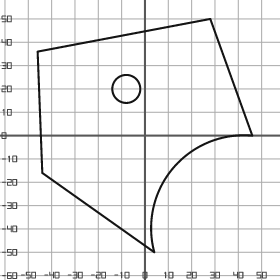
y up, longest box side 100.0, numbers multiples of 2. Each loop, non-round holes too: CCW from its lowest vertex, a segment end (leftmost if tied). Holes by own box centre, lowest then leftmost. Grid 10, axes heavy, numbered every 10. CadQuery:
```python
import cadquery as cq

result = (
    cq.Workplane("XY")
    .moveTo(4.0, -50.0)
    .threePointArc((12.0, -14.0), (46.0, 0.0))
    .lineTo(28.0, 50.0)
    .lineTo(-46.0, 36.0)
    .lineTo(-44.0, -16.0)
    .close()
    .moveTo(-8.0, 20.0)
    .circle(6.0)
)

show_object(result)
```